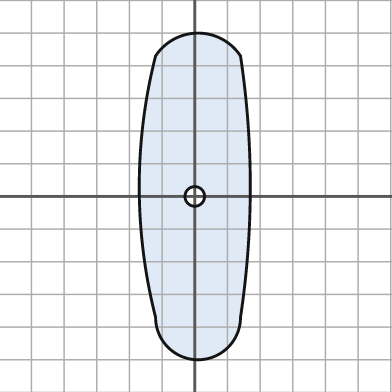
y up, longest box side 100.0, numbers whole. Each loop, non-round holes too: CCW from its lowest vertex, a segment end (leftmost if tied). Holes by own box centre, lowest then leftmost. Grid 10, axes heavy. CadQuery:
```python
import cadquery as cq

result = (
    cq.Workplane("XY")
    .moveTo(-12.0, -37.0)
    .threePointArc((1.0, -50.0), (14.0, -37.0))
    .threePointArc((17.0, 3.0), (14.0, 43.0))
    .threePointArc((1.0, 50.0), (-12.0, 43.0))
    .threePointArc((-17.0, 3.0), (-12.0, -37.0))
    .close()
    .moveTo(0.0, 0.0)
    .circle(3.0)
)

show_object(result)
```